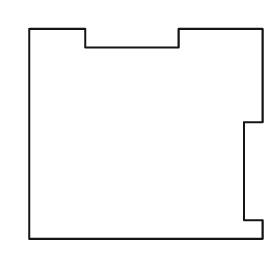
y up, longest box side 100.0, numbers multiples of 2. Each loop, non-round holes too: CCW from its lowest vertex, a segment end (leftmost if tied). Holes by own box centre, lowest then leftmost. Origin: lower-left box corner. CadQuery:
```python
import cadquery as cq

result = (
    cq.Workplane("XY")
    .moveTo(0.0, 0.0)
    .lineTo(100.0, 0.0)
    .lineTo(100.0, 8.0)
    .lineTo(92.0, 8.0)
    .lineTo(92.0, 50.0)
    .lineTo(100.0, 50.0)
    .lineTo(100.0, 90.0)
    .lineTo(64.0, 90.0)
    .lineTo(64.0, 82.0)
    .lineTo(24.0, 82.0)
    .lineTo(24.0, 90.0)
    .lineTo(0.0, 90.0)
    .close()
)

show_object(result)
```